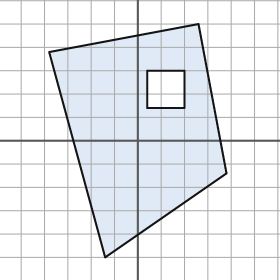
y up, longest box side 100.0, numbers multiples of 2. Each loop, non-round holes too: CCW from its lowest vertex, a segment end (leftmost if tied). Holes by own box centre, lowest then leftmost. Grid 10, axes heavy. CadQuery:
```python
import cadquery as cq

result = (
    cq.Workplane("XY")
    .moveTo(-14.0, -50.0)
    .lineTo(38.0, -14.0)
    .lineTo(26.0, 50.0)
    .lineTo(-38.0, 38.0)
    .close()
    .moveTo(4.0, 14.0)
    .lineTo(20.0, 14.0)
    .lineTo(20.0, 30.0)
    .lineTo(4.0, 30.0)
    .close()
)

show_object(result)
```